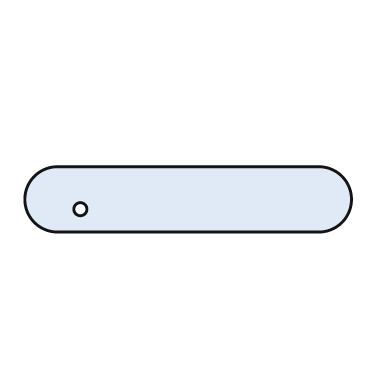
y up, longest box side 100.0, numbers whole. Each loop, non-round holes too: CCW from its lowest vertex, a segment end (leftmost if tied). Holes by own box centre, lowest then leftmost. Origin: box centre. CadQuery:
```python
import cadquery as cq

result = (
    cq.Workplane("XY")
    .moveTo(-40.0, -10.0)
    .lineTo(40.0, -10.0)
    .threePointArc((50.0, 0.0), (40.0, 10.0))
    .lineTo(-40.0, 10.0)
    .threePointArc((-50.0, 0.0), (-40.0, -10.0))
    .close()
    .moveTo(-33.0, -3.0)
    .circle(2.0)
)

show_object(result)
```